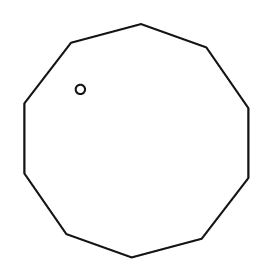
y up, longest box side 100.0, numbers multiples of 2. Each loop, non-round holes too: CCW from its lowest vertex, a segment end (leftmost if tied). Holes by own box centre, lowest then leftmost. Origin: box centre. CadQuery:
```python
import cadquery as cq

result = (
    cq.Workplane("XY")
    .moveTo(-2.0, -50.0)
    .lineTo(28.0, -42.0)
    .lineTo(48.0, -16.0)
    .lineTo(48.0, 14.0)
    .lineTo(30.0, 40.0)
    .lineTo(2.0, 50.0)
    .lineTo(-28.0, 42.0)
    .lineTo(-48.0, 16.0)
    .lineTo(-48.0, -14.0)
    .lineTo(-30.0, -40.0)
    .close()
    .moveTo(-24.0, 22.0)
    .circle(2.0)
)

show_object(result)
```